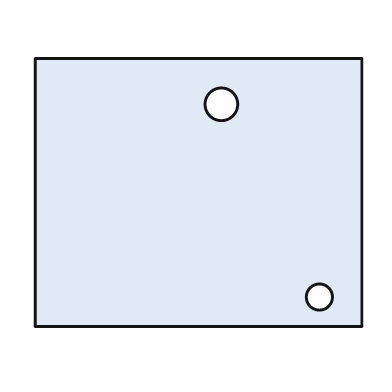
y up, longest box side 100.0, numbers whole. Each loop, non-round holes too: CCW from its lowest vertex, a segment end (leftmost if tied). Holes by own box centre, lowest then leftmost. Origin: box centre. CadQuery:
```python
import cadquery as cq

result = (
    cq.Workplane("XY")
    .moveTo(-50.0, -41.0)
    .lineTo(50.0, -41.0)
    .lineTo(50.0, 41.0)
    .lineTo(-50.0, 41.0)
    .close()
    .moveTo(37.0, -32.0)
    .circle(4.0)
    .moveTo(7.0, 27.0)
    .circle(5.0)
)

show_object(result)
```